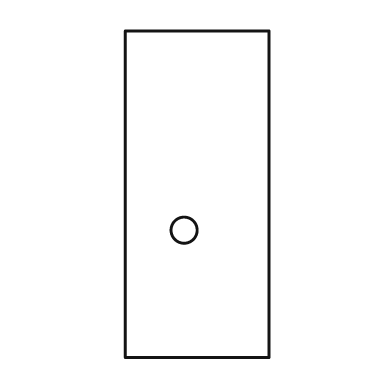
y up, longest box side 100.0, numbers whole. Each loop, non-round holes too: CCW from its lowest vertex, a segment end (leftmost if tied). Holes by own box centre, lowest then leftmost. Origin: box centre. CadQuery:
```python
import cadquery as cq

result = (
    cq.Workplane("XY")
    .moveTo(-22.0, -50.0)
    .lineTo(22.0, -50.0)
    .lineTo(22.0, 50.0)
    .lineTo(-22.0, 50.0)
    .close()
    .moveTo(-4.0, -11.0)
    .circle(4.0)
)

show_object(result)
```